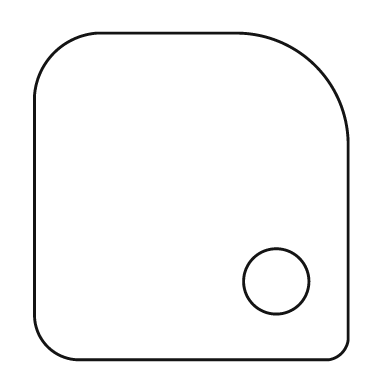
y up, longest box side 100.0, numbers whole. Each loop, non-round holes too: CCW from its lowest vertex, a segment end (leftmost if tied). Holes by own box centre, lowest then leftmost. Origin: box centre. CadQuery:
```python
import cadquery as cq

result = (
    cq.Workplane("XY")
    .moveTo(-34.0, -50.0)
    .lineTo(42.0, -50.0)
    .threePointArc((46.0, -48.0), (48.0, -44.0))
    .lineTo(48.0, 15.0)
    .threePointArc((38.0, 40.0), (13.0, 50.0))
    .lineTo(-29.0, 50.0)
    .threePointArc((-42.0, 44.0), (-48.0, 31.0))
    .lineTo(-48.0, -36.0)
    .threePointArc((-44.0, -46.0), (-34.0, -50.0))
    .close()
    .moveTo(26.0, -26.0)
    .circle(10.0)
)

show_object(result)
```